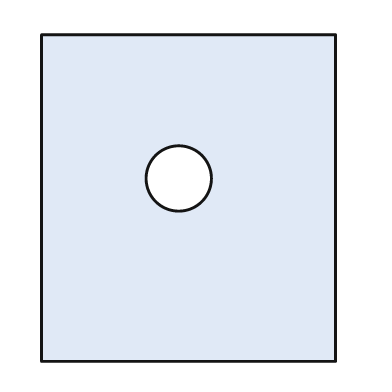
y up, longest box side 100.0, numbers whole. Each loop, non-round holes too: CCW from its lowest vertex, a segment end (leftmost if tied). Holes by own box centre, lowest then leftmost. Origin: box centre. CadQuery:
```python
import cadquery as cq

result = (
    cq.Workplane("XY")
    .moveTo(-45.0, -50.0)
    .lineTo(45.0, -50.0)
    .lineTo(45.0, 50.0)
    .lineTo(-45.0, 50.0)
    .close()
    .moveTo(-3.0, 6.0)
    .circle(10.0)
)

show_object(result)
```